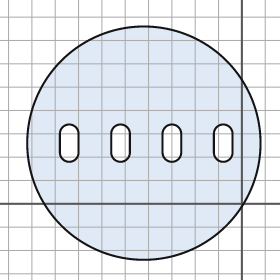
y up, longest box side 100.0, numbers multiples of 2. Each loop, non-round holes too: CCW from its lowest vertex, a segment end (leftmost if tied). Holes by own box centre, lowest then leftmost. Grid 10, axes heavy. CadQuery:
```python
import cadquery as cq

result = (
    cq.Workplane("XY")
    .moveTo(-42.0, 26.0)
    .circle(50.0)
    .moveTo(-78.0, 22.0)
    .threePointArc((-74.0, 18.0), (-70.0, 22.0))
    .lineTo(-70.0, 30.0)
    .threePointArc((-74.0, 34.0), (-78.0, 30.0))
    .close()
    .moveTo(-56.0, 22.0)
    .threePointArc((-52.0, 18.0), (-48.0, 22.0))
    .lineTo(-48.0, 30.0)
    .threePointArc((-52.0, 34.0), (-56.0, 30.0))
    .close()
    .moveTo(-34.0, 22.0)
    .threePointArc((-30.0, 18.0), (-26.0, 22.0))
    .lineTo(-26.0, 30.0)
    .threePointArc((-30.0, 34.0), (-34.0, 30.0))
    .close()
    .moveTo(-12.0, 22.0)
    .threePointArc((-8.0, 18.0), (-4.0, 22.0))
    .lineTo(-4.0, 30.0)
    .threePointArc((-8.0, 34.0), (-12.0, 30.0))
    .close()
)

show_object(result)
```